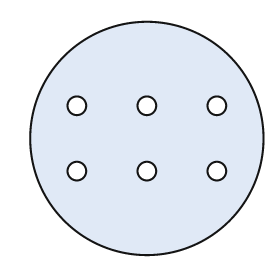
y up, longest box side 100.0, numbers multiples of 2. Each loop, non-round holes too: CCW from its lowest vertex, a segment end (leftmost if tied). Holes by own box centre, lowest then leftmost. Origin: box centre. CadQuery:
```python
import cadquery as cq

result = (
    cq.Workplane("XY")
    .moveTo(0.0, 0.0)
    .circle(50.0)
    .moveTo(-30.0, -14.0)
    .circle(4.0)
    .moveTo(0.0, -14.0)
    .circle(4.0)
    .moveTo(30.0, -14.0)
    .circle(4.0)
    .moveTo(-30.0, 14.0)
    .circle(4.0)
    .moveTo(0.0, 14.0)
    .circle(4.0)
    .moveTo(30.0, 14.0)
    .circle(4.0)
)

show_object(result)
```